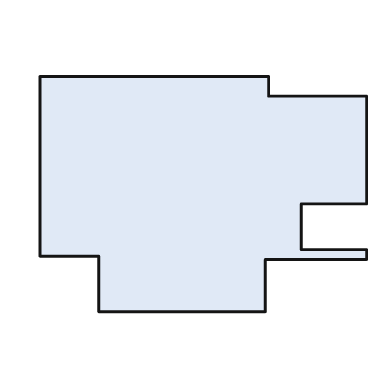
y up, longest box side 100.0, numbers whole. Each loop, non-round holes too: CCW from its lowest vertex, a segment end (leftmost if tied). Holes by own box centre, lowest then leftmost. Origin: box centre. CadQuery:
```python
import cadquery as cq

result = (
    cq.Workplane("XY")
    .moveTo(-32.0, -36.0)
    .lineTo(19.0, -36.0)
    .lineTo(19.0, -20.0)
    .lineTo(50.0, -20.0)
    .lineTo(50.0, -17.0)
    .lineTo(30.0, -17.0)
    .lineTo(30.0, -3.0)
    .lineTo(50.0, -3.0)
    .lineTo(50.0, 30.0)
    .lineTo(20.0, 30.0)
    .lineTo(20.0, 36.0)
    .lineTo(-50.0, 36.0)
    .lineTo(-50.0, -19.0)
    .lineTo(-32.0, -19.0)
    .close()
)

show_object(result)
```